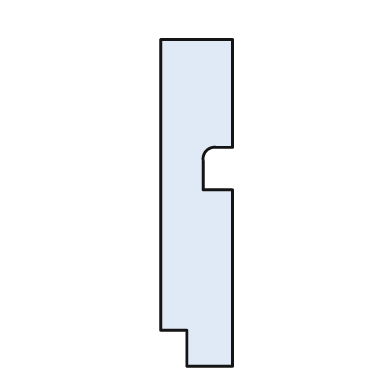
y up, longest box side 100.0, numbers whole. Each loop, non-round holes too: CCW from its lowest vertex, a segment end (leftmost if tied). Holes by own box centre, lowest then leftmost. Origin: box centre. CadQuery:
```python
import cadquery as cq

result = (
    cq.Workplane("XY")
    .moveTo(-3.0, -50.0)
    .lineTo(11.0, -50.0)
    .lineTo(11.0, 4.0)
    .lineTo(2.0, 4.0)
    .lineTo(2.0, 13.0)
    .threePointArc((3.0, 16.0), (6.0, 17.0))
    .lineTo(11.0, 17.0)
    .lineTo(11.0, 50.0)
    .lineTo(-11.0, 50.0)
    .lineTo(-11.0, -39.0)
    .lineTo(-3.0, -39.0)
    .close()
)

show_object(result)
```